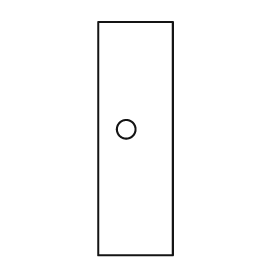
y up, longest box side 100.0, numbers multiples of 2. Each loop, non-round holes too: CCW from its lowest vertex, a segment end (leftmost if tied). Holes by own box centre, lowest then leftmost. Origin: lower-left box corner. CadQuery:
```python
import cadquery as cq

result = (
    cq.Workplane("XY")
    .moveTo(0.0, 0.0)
    .lineTo(32.0, 0.0)
    .lineTo(32.0, 100.0)
    .lineTo(0.0, 100.0)
    .close()
    .moveTo(12.0, 54.0)
    .circle(4.0)
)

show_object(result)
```